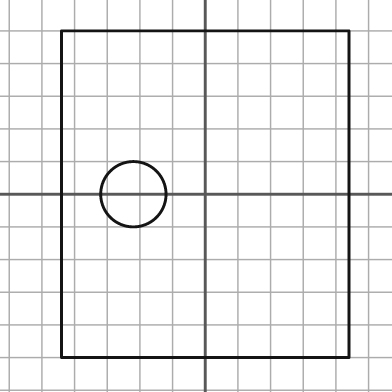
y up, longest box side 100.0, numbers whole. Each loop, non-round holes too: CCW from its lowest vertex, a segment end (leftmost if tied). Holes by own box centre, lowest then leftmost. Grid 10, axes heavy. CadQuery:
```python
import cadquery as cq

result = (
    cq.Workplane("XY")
    .moveTo(-44.0, -50.0)
    .lineTo(44.0, -50.0)
    .lineTo(44.0, 50.0)
    .lineTo(-44.0, 50.0)
    .close()
    .moveTo(-22.0, 0.0)
    .circle(10.0)
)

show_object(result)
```